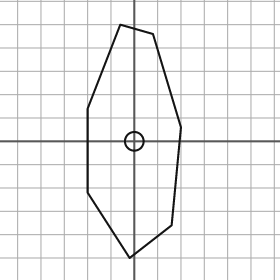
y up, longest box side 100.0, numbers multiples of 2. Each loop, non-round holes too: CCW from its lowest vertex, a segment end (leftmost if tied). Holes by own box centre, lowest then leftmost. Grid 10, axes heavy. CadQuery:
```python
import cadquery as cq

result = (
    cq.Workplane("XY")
    .moveTo(-2.0, -50.0)
    .lineTo(16.0, -36.0)
    .lineTo(20.0, 6.0)
    .lineTo(8.0, 46.0)
    .lineTo(-6.0, 50.0)
    .lineTo(-20.0, 14.0)
    .lineTo(-20.0, -22.0)
    .close()
    .moveTo(0.0, 0.0)
    .circle(4.0)
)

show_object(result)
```